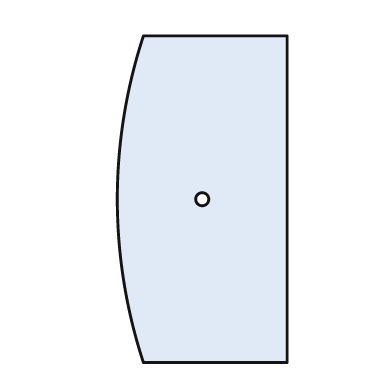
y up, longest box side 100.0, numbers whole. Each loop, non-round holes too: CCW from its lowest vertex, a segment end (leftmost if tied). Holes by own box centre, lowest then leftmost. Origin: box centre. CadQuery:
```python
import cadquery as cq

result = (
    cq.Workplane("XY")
    .moveTo(-18.0, -50.0)
    .lineTo(26.0, -50.0)
    .lineTo(26.0, 50.0)
    .lineTo(-18.0, 50.0)
    .threePointArc((-26.0, 0.0), (-18.0, -50.0))
    .close()
    .moveTo(0.0, 0.0)
    .circle(2.0)
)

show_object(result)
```